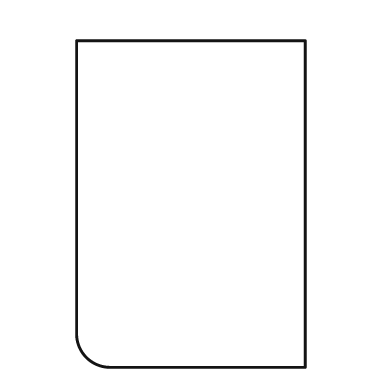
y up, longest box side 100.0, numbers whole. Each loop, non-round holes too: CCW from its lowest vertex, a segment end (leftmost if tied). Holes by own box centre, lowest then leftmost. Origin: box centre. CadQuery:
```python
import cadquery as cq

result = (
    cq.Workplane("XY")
    .moveTo(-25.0, -50.0)
    .lineTo(35.0, -50.0)
    .lineTo(35.0, 50.0)
    .lineTo(-35.0, 50.0)
    .lineTo(-35.0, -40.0)
    .threePointArc((-32.0, -47.0), (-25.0, -50.0))
    .close()
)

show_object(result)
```